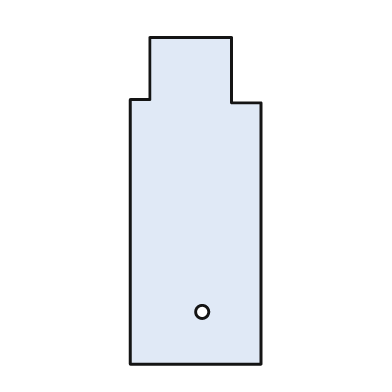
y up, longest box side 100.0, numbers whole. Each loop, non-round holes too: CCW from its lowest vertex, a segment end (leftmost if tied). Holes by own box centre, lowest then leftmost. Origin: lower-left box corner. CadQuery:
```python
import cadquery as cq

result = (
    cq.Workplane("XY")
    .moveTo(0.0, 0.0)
    .lineTo(40.0, 0.0)
    .lineTo(40.0, 80.0)
    .lineTo(31.0, 80.0)
    .lineTo(31.0, 100.0)
    .lineTo(6.0, 100.0)
    .lineTo(6.0, 81.0)
    .lineTo(0.0, 81.0)
    .close()
    .moveTo(22.0, 16.0)
    .circle(2.0)
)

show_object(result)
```